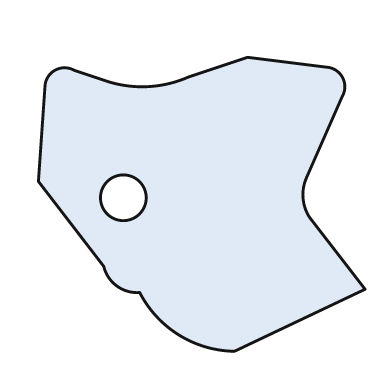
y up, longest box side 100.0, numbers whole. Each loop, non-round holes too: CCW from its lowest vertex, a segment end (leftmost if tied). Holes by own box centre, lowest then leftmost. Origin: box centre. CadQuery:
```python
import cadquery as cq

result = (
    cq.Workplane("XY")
    .moveTo(10.0, -45.0)
    .lineTo(50.0, -26.0)
    .lineTo(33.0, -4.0)
    .threePointArc((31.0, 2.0), (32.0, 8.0))
    .lineTo(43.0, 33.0)
    .threePointArc((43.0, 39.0), (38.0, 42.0))
    .lineTo(14.0, 45.0)
    .lineTo(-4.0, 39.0)
    .threePointArc((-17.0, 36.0), (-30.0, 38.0))
    .lineTo(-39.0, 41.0)
    .threePointArc((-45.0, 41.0), (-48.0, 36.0))
    .lineTo(-50.0, 7.0)
    .lineTo(-30.0, -19.0)
    .threePointArc((-26.0, -25.0), (-19.0, -27.0))
    .threePointArc((-7.0, -40.0), (10.0, -45.0))
    .close()
    .moveTo(-24.0, 2.0)
    .circle(7.0)
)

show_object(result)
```